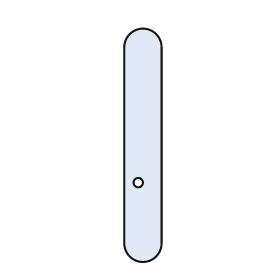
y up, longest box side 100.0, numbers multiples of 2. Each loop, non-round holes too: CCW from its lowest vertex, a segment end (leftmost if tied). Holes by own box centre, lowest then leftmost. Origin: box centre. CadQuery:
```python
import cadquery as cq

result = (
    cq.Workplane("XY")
    .moveTo(-8.0, -42.0)
    .threePointArc((0.0, -50.0), (8.0, -42.0))
    .lineTo(8.0, 42.0)
    .threePointArc((0.0, 50.0), (-8.0, 42.0))
    .close()
    .moveTo(-2.0, -16.0)
    .circle(2.0)
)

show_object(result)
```